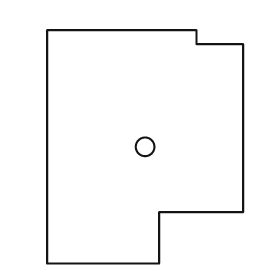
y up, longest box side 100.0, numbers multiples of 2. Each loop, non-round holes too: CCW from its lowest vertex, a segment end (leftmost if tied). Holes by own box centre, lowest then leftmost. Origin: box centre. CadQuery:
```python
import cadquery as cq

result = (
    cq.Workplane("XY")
    .moveTo(-42.0, -50.0)
    .lineTo(6.0, -50.0)
    .lineTo(6.0, -28.0)
    .lineTo(42.0, -28.0)
    .lineTo(42.0, 44.0)
    .lineTo(22.0, 44.0)
    .lineTo(22.0, 50.0)
    .lineTo(-42.0, 50.0)
    .close()
    .moveTo(0.0, 0.0)
    .circle(4.0)
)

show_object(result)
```